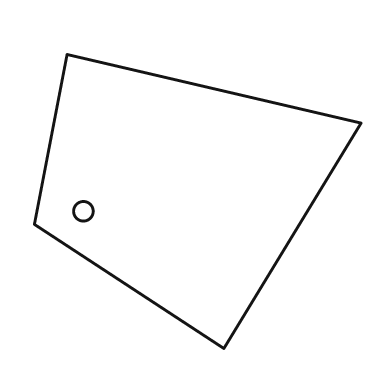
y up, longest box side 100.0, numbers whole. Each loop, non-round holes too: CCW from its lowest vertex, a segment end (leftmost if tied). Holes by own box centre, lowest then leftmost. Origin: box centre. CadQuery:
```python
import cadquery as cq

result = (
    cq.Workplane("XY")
    .moveTo(8.0, -45.0)
    .lineTo(50.0, 24.0)
    .lineTo(-40.0, 45.0)
    .lineTo(-50.0, -7.0)
    .close()
    .moveTo(-35.0, -3.0)
    .circle(3.0)
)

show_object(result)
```